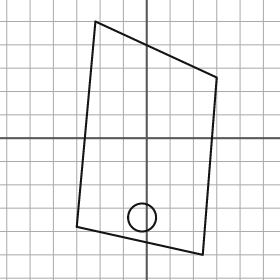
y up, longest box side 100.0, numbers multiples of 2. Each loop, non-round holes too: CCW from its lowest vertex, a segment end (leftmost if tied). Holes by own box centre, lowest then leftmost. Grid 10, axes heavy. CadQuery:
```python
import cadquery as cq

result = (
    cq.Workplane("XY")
    .moveTo(24.0, -50.0)
    .lineTo(30.0, 26.0)
    .lineTo(-22.0, 50.0)
    .lineTo(-30.0, -38.0)
    .close()
    .moveTo(-2.0, -34.0)
    .circle(6.0)
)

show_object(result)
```